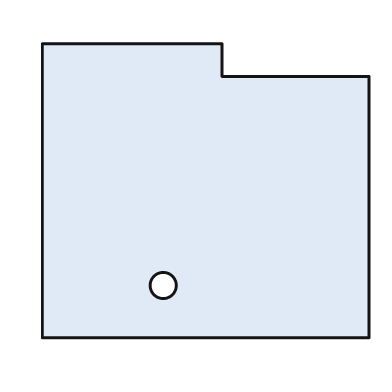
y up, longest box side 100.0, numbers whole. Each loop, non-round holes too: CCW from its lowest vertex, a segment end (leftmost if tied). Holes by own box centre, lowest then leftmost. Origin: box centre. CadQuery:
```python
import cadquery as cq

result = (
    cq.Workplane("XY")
    .moveTo(-50.0, -45.0)
    .lineTo(50.0, -45.0)
    .lineTo(50.0, 35.0)
    .lineTo(5.0, 35.0)
    .lineTo(5.0, 45.0)
    .lineTo(-50.0, 45.0)
    .close()
    .moveTo(-13.0, -29.0)
    .circle(4.0)
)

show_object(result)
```